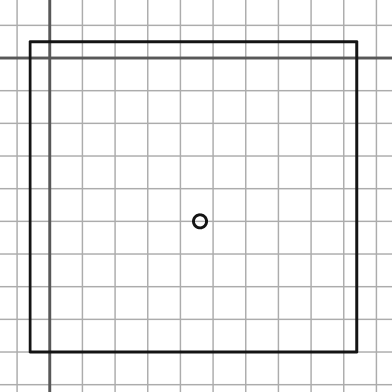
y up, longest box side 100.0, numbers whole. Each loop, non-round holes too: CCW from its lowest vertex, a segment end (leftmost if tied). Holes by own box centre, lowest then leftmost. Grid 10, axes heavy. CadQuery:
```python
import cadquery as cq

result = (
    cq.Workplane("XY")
    .moveTo(-6.0, -90.0)
    .lineTo(94.0, -90.0)
    .lineTo(94.0, 5.0)
    .lineTo(-6.0, 5.0)
    .close()
    .moveTo(46.0, -50.0)
    .circle(2.0)
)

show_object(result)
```